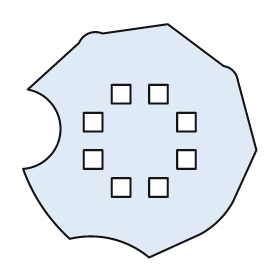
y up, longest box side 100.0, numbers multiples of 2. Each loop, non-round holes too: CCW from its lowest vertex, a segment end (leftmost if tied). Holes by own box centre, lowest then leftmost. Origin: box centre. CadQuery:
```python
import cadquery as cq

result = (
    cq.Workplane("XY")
    .moveTo(4.0, -50.0)
    .lineTo(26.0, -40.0)
    .threePointArc((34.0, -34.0), (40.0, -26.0))
    .lineTo(50.0, -4.0)
    .lineTo(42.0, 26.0)
    .threePointArc((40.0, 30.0), (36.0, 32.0))
    .lineTo(12.0, 50.0)
    .lineTo(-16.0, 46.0)
    .threePointArc((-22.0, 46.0), (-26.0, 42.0))
    .lineTo(-48.0, 22.0)
    .threePointArc((-34.0, 4.0), (-50.0, -12.0))
    .threePointArc((-42.0, -28.0), (-30.0, -42.0))
    .threePointArc((-12.0, -42.0), (4.0, -50.0))
    .close()
    .moveTo(-12.0, -24.0)
    .lineTo(-4.0, -24.0)
    .lineTo(-4.0, -16.0)
    .lineTo(-12.0, -16.0)
    .close()
    .moveTo(4.0, -24.0)
    .lineTo(12.0, -24.0)
    .lineTo(12.0, -16.0)
    .lineTo(4.0, -16.0)
    .close()
    .moveTo(-24.0, -12.0)
    .lineTo(-16.0, -12.0)
    .lineTo(-16.0, -4.0)
    .lineTo(-24.0, -4.0)
    .close()
    .moveTo(16.0, -12.0)
    .lineTo(24.0, -12.0)
    .lineTo(24.0, -4.0)
    .lineTo(16.0, -4.0)
    .close()
    .moveTo(-24.0, 4.0)
    .lineTo(-16.0, 4.0)
    .lineTo(-16.0, 12.0)
    .lineTo(-24.0, 12.0)
    .close()
    .moveTo(16.0, 4.0)
    .lineTo(24.0, 4.0)
    .lineTo(24.0, 12.0)
    .lineTo(16.0, 12.0)
    .close()
    .moveTo(-12.0, 16.0)
    .lineTo(-4.0, 16.0)
    .lineTo(-4.0, 24.0)
    .lineTo(-12.0, 24.0)
    .close()
    .moveTo(4.0, 16.0)
    .lineTo(12.0, 16.0)
    .lineTo(12.0, 24.0)
    .lineTo(4.0, 24.0)
    .close()
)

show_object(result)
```